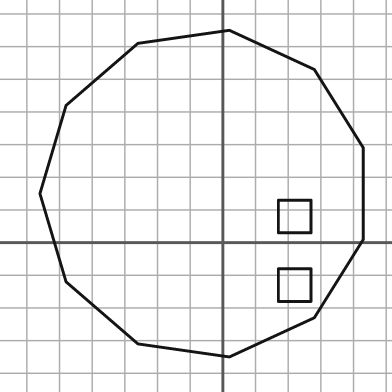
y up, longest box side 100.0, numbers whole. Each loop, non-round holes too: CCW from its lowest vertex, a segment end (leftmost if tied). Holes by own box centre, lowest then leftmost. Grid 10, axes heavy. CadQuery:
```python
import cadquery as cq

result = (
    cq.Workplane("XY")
    .moveTo(2.0, -35.0)
    .lineTo(28.0, -23.0)
    .lineTo(43.0, 1.0)
    .lineTo(43.0, 29.0)
    .lineTo(28.0, 53.0)
    .lineTo(2.0, 65.0)
    .lineTo(-26.0, 61.0)
    .lineTo(-48.0, 42.0)
    .lineTo(-56.0, 15.0)
    .lineTo(-48.0, -12.0)
    .lineTo(-26.0, -31.0)
    .close()
    .moveTo(17.0, -18.0)
    .lineTo(27.0, -18.0)
    .lineTo(27.0, -8.0)
    .lineTo(17.0, -8.0)
    .close()
    .moveTo(17.0, 3.0)
    .lineTo(27.0, 3.0)
    .lineTo(27.0, 13.0)
    .lineTo(17.0, 13.0)
    .close()
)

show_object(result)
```